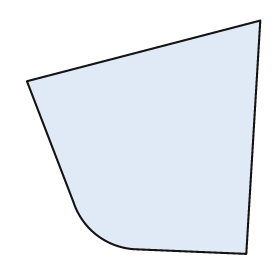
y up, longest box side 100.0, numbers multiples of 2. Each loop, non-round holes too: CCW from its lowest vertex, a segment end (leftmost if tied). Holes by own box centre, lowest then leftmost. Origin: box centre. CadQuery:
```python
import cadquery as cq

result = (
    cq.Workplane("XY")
    .moveTo(44.0, -50.0)
    .lineTo(50.0, 50.0)
    .lineTo(-50.0, 24.0)
    .lineTo(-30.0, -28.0)
    .threePointArc((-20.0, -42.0), (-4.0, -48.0))
    .close()
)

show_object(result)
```